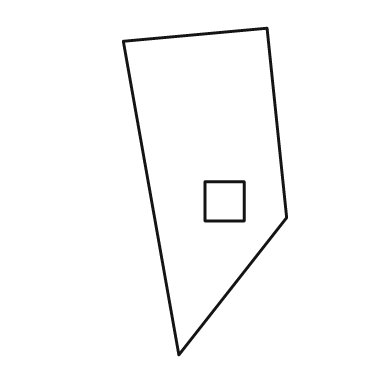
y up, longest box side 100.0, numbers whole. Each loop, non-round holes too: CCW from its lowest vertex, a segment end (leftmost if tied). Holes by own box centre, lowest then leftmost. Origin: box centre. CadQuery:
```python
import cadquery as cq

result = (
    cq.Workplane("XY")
    .moveTo(-8.0, -50.0)
    .lineTo(25.0, -8.0)
    .lineTo(19.0, 50.0)
    .lineTo(-25.0, 46.0)
    .close()
    .moveTo(0.0, -9.0)
    .lineTo(12.0, -9.0)
    .lineTo(12.0, 3.0)
    .lineTo(0.0, 3.0)
    .close()
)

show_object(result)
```